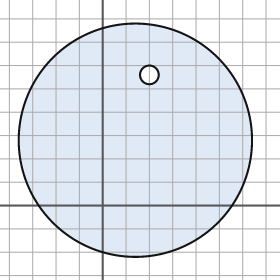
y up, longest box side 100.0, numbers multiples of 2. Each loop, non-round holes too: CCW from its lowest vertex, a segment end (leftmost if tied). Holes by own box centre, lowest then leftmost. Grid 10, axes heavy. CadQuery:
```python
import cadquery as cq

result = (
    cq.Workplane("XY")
    .moveTo(14.0, 28.0)
    .circle(50.0)
    .moveTo(20.0, 56.0)
    .circle(4.0)
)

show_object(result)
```